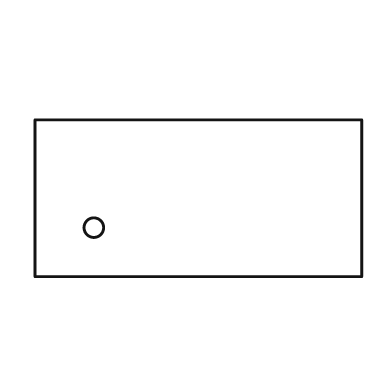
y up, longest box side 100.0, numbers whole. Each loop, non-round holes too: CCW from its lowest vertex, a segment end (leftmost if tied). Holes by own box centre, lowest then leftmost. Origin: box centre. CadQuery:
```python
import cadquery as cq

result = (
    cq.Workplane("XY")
    .moveTo(-50.0, -24.0)
    .lineTo(50.0, -24.0)
    .lineTo(50.0, 24.0)
    .lineTo(-50.0, 24.0)
    .close()
    .moveTo(-32.0, -9.0)
    .circle(3.0)
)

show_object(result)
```